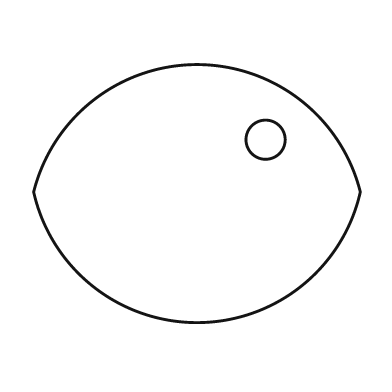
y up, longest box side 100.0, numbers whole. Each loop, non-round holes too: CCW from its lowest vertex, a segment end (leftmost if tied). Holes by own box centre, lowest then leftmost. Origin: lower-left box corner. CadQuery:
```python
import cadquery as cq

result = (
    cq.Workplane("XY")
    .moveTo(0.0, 40.0)
    .threePointArc((50.0, 0.0), (100.0, 40.0))
    .threePointArc((50.0, 79.0), (0.0, 40.0))
    .close()
    .moveTo(71.0, 56.0)
    .circle(6.0)
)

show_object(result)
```